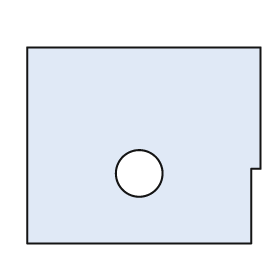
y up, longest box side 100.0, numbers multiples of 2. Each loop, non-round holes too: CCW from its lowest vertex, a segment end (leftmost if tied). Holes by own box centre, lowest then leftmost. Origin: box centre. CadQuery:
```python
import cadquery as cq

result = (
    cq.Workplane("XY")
    .moveTo(-50.0, -42.0)
    .lineTo(46.0, -42.0)
    .lineTo(46.0, -10.0)
    .lineTo(50.0, -10.0)
    .lineTo(50.0, 42.0)
    .lineTo(-50.0, 42.0)
    .close()
    .moveTo(-2.0, -12.0)
    .circle(10.0)
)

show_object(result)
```